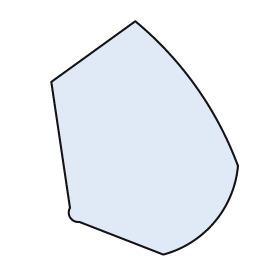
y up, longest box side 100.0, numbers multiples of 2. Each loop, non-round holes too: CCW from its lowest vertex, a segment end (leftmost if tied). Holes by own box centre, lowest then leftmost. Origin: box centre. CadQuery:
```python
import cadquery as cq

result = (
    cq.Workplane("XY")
    .moveTo(8.0, -50.0)
    .threePointArc((30.0, -36.0), (40.0, -12.0))
    .threePointArc((22.0, 22.0), (-4.0, 50.0))
    .lineTo(-40.0, 24.0)
    .lineTo(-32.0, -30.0)
    .threePointArc((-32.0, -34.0), (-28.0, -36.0))
    .close()
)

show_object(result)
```